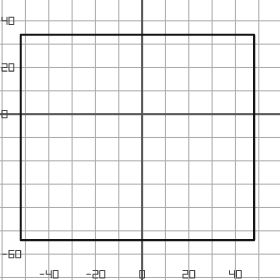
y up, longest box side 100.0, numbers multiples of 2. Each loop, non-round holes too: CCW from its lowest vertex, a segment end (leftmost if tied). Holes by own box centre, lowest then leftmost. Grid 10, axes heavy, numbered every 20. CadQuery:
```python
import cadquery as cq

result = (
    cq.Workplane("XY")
    .moveTo(-52.0, -54.0)
    .lineTo(48.0, -54.0)
    .lineTo(48.0, 34.0)
    .lineTo(-52.0, 34.0)
    .close()
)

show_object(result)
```